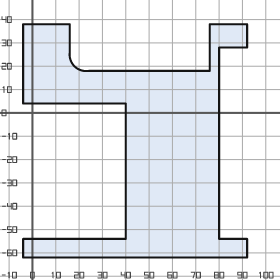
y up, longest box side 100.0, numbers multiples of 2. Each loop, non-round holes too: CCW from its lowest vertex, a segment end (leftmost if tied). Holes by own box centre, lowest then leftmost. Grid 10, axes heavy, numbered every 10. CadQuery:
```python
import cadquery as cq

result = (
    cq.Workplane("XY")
    .moveTo(-4.0, -62.0)
    .lineTo(92.0, -62.0)
    .lineTo(92.0, -54.0)
    .lineTo(80.0, -54.0)
    .lineTo(80.0, 28.0)
    .lineTo(92.0, 28.0)
    .lineTo(92.0, 38.0)
    .lineTo(76.0, 38.0)
    .lineTo(76.0, 18.0)
    .lineTo(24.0, 18.0)
    .threePointArc((18.0, 20.0), (16.0, 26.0))
    .lineTo(16.0, 38.0)
    .lineTo(-4.0, 38.0)
    .lineTo(-4.0, 4.0)
    .lineTo(40.0, 4.0)
    .lineTo(40.0, -54.0)
    .lineTo(-4.0, -54.0)
    .close()
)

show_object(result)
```